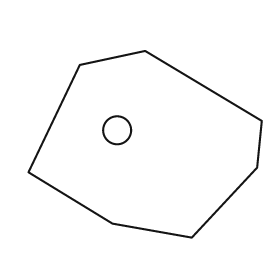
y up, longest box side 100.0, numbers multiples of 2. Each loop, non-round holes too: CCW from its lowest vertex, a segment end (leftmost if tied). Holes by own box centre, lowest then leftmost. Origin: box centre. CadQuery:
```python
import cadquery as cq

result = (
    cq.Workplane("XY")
    .moveTo(20.0, -40.0)
    .lineTo(48.0, -10.0)
    .lineTo(50.0, 10.0)
    .lineTo(0.0, 40.0)
    .lineTo(-28.0, 34.0)
    .lineTo(-50.0, -12.0)
    .lineTo(-14.0, -34.0)
    .close()
    .moveTo(-12.0, 6.0)
    .circle(6.0)
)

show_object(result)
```